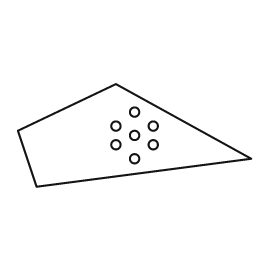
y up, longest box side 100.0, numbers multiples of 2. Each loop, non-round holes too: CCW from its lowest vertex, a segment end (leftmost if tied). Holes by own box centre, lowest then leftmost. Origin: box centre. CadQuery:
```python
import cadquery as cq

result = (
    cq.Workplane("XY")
    .moveTo(-42.0, -22.0)
    .lineTo(50.0, -10.0)
    .lineTo(-8.0, 22.0)
    .lineTo(-50.0, 2.0)
    .close()
    .moveTo(0.0, -10.0)
    .circle(2.0)
    .moveTo(-8.0, -4.0)
    .circle(2.0)
    .moveTo(8.0, -4.0)
    .circle(2.0)
    .moveTo(0.0, 0.0)
    .circle(2.0)
    .moveTo(-8.0, 4.0)
    .circle(2.0)
    .moveTo(8.0, 4.0)
    .circle(2.0)
    .moveTo(0.0, 10.0)
    .circle(2.0)
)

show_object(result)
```